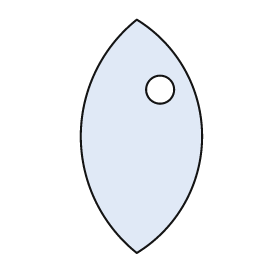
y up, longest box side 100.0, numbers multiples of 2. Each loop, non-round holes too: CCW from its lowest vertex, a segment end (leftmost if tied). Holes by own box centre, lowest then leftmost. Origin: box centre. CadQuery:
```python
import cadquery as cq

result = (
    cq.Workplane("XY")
    .moveTo(-2.0, -50.0)
    .threePointArc((26.0, 0.0), (-2.0, 50.0))
    .threePointArc((-26.0, 0.0), (-2.0, -50.0))
    .close()
    .moveTo(8.0, 20.0)
    .circle(6.0)
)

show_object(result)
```